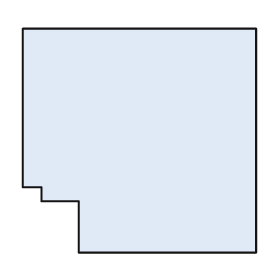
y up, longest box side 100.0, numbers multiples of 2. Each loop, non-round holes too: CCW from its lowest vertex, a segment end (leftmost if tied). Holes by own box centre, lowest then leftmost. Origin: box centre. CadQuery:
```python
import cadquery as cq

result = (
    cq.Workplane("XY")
    .moveTo(-26.0, -48.0)
    .lineTo(50.0, -48.0)
    .lineTo(50.0, 48.0)
    .lineTo(-50.0, 48.0)
    .lineTo(-50.0, -20.0)
    .lineTo(-42.0, -20.0)
    .lineTo(-42.0, -26.0)
    .lineTo(-26.0, -26.0)
    .close()
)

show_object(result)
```